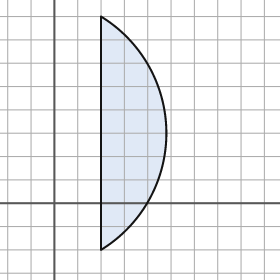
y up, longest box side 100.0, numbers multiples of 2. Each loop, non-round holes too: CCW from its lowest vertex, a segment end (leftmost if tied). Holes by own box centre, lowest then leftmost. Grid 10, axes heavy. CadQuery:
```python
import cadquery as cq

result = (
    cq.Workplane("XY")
    .moveTo(20.0, -20.0)
    .threePointArc((48.0, 30.0), (20.0, 80.0))
    .close()
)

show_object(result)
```